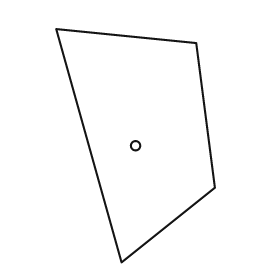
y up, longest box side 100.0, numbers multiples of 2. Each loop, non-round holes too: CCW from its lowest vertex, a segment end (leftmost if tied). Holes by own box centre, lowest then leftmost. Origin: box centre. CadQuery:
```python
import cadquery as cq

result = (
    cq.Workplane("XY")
    .moveTo(-6.0, -50.0)
    .lineTo(34.0, -18.0)
    .lineTo(26.0, 44.0)
    .lineTo(-34.0, 50.0)
    .close()
    .moveTo(0.0, 0.0)
    .circle(2.0)
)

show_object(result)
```